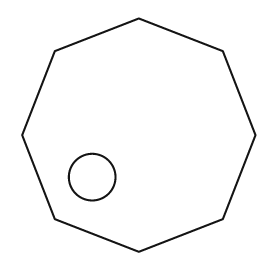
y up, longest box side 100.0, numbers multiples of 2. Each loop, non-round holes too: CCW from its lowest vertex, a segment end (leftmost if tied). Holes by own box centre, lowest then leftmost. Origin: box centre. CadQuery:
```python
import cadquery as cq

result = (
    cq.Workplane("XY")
    .moveTo(0.0, -50.0)
    .lineTo(36.0, -36.0)
    .lineTo(50.0, 0.0)
    .lineTo(36.0, 36.0)
    .lineTo(0.0, 50.0)
    .lineTo(-36.0, 36.0)
    .lineTo(-50.0, 0.0)
    .lineTo(-36.0, -36.0)
    .close()
    .moveTo(-20.0, -18.0)
    .circle(10.0)
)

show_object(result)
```